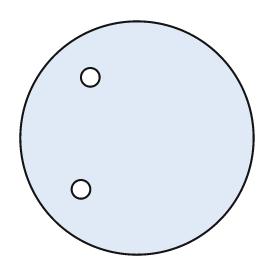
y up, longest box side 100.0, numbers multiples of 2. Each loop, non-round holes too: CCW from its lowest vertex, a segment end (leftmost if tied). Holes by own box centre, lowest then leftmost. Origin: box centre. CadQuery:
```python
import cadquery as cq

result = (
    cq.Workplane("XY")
    .moveTo(0.0, 0.0)
    .circle(50.0)
    .moveTo(-24.0, -22.0)
    .circle(4.0)
    .moveTo(-20.0, 26.0)
    .circle(4.0)
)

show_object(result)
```